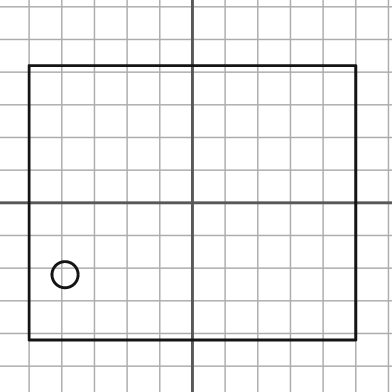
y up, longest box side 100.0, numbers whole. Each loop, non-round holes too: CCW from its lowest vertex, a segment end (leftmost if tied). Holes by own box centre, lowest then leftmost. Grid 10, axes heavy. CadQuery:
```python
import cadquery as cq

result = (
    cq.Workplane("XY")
    .moveTo(-50.0, -42.0)
    .lineTo(50.0, -42.0)
    .lineTo(50.0, 42.0)
    .lineTo(-50.0, 42.0)
    .close()
    .moveTo(-39.0, -22.0)
    .circle(4.0)
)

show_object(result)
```